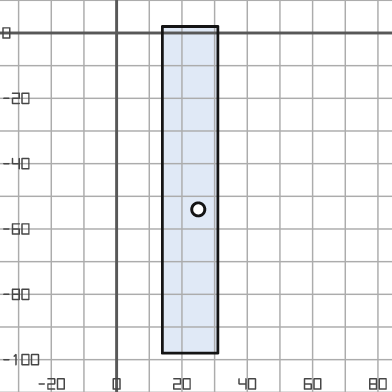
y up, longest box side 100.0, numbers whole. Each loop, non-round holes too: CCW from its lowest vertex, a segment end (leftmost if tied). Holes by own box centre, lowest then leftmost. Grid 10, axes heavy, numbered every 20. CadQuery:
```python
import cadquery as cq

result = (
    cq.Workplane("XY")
    .moveTo(14.0, -98.0)
    .lineTo(31.0, -98.0)
    .lineTo(31.0, 2.0)
    .lineTo(14.0, 2.0)
    .close()
    .moveTo(25.0, -54.0)
    .circle(2.0)
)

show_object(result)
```